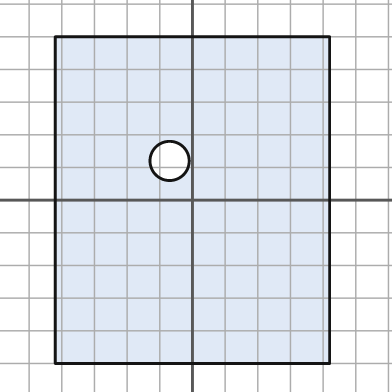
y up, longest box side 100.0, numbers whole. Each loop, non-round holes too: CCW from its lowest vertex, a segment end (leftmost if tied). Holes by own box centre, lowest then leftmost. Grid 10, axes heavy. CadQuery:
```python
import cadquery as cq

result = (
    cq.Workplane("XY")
    .moveTo(-42.0, -50.0)
    .lineTo(42.0, -50.0)
    .lineTo(42.0, 50.0)
    .lineTo(-42.0, 50.0)
    .close()
    .moveTo(-7.0, 12.0)
    .circle(6.0)
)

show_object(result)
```